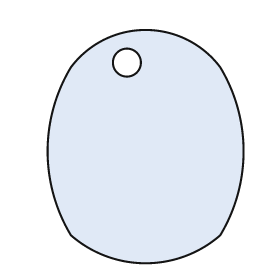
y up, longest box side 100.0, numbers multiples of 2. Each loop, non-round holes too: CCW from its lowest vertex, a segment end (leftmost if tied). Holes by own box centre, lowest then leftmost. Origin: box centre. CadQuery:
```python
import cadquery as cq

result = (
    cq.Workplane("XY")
    .moveTo(-32.0, -38.0)
    .threePointArc((0.0, -50.0), (32.0, -38.0))
    .threePointArc((42.0, -2.0), (32.0, 34.0))
    .threePointArc((0.0, 50.0), (-32.0, 34.0))
    .threePointArc((-42.0, -2.0), (-32.0, -38.0))
    .close()
    .moveTo(-8.0, 36.0)
    .circle(6.0)
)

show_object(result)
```